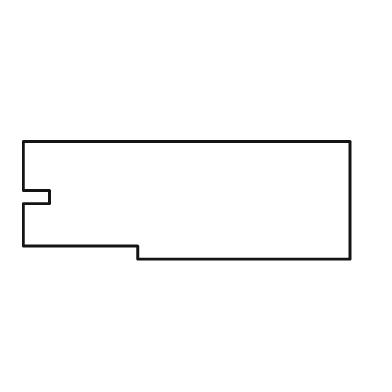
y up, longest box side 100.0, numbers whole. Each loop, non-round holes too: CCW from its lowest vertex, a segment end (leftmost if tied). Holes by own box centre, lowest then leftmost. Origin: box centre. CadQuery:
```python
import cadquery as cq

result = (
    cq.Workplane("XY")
    .moveTo(-15.0, -18.0)
    .lineTo(50.0, -18.0)
    .lineTo(50.0, 18.0)
    .lineTo(-50.0, 18.0)
    .lineTo(-50.0, 3.0)
    .lineTo(-42.0, 3.0)
    .lineTo(-42.0, -1.0)
    .lineTo(-50.0, -1.0)
    .lineTo(-50.0, -14.0)
    .lineTo(-15.0, -14.0)
    .close()
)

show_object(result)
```